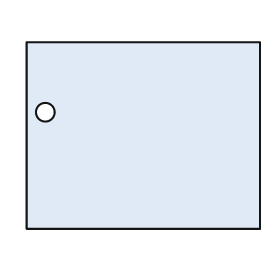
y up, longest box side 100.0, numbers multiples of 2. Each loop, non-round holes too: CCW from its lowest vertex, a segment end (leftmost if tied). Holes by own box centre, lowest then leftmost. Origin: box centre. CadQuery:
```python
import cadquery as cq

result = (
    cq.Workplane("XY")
    .moveTo(-50.0, -40.0)
    .lineTo(50.0, -40.0)
    .lineTo(50.0, 40.0)
    .lineTo(-50.0, 40.0)
    .close()
    .moveTo(-42.0, 10.0)
    .circle(4.0)
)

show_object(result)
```